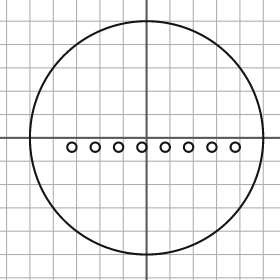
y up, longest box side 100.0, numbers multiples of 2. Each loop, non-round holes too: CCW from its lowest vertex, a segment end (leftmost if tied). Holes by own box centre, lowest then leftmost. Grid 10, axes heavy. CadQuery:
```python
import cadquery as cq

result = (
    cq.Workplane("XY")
    .moveTo(0.0, 0.0)
    .circle(50.0)
    .moveTo(-32.0, -4.0)
    .circle(2.0)
    .moveTo(-22.0, -4.0)
    .circle(2.0)
    .moveTo(-12.0, -4.0)
    .circle(2.0)
    .moveTo(-2.0, -4.0)
    .circle(2.0)
    .moveTo(8.0, -4.0)
    .circle(2.0)
    .moveTo(18.0, -4.0)
    .circle(2.0)
    .moveTo(28.0, -4.0)
    .circle(2.0)
    .moveTo(38.0, -4.0)
    .circle(2.0)
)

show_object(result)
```